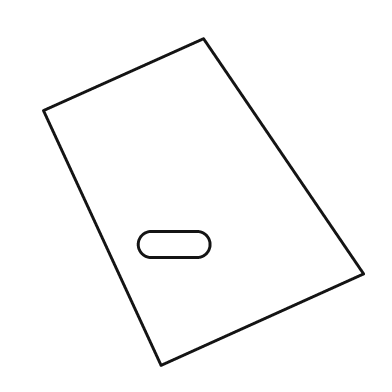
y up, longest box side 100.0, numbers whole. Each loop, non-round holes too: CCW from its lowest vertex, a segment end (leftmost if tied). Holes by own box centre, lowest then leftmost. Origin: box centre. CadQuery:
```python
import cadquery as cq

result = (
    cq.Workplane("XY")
    .moveTo(-13.0, -50.0)
    .lineTo(49.0, -22.0)
    .lineTo(0.0, 50.0)
    .lineTo(-49.0, 28.0)
    .close()
    .moveTo(-16.0, -17.0)
    .lineTo(-2.0, -17.0)
    .threePointArc((2.0, -13.0), (-2.0, -9.0))
    .lineTo(-16.0, -9.0)
    .threePointArc((-20.0, -13.0), (-16.0, -17.0))
    .close()
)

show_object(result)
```